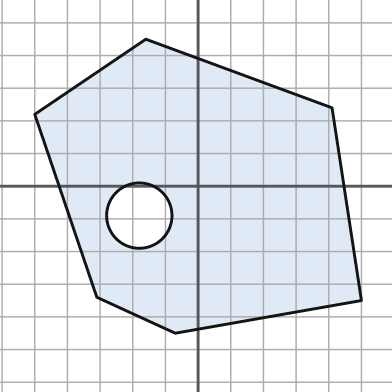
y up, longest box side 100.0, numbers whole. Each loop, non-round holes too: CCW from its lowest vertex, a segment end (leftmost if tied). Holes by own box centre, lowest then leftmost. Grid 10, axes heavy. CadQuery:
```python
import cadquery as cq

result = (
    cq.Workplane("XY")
    .moveTo(-7.0, -45.0)
    .lineTo(50.0, -35.0)
    .lineTo(41.0, 24.0)
    .lineTo(-16.0, 45.0)
    .lineTo(-50.0, 22.0)
    .lineTo(-31.0, -34.0)
    .close()
    .moveTo(-18.0, -9.0)
    .circle(10.0)
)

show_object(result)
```